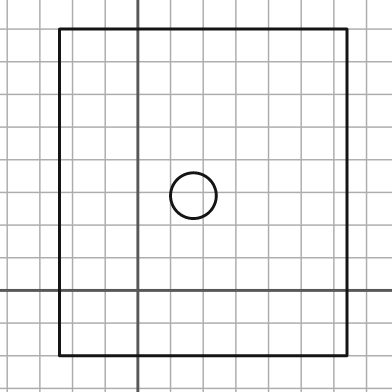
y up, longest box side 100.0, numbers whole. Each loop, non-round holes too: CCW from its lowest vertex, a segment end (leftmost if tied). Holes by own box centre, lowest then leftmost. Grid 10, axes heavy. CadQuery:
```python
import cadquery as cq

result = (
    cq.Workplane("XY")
    .moveTo(-24.0, -20.0)
    .lineTo(64.0, -20.0)
    .lineTo(64.0, 80.0)
    .lineTo(-24.0, 80.0)
    .close()
    .moveTo(17.0, 29.0)
    .circle(7.0)
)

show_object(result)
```